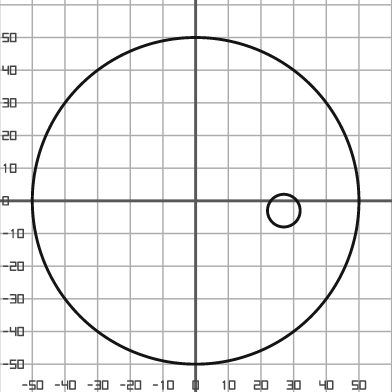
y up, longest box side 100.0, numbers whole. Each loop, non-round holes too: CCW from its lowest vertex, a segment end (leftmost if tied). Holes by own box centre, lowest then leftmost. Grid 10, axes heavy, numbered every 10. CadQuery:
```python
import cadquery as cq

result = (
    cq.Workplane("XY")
    .moveTo(0.0, 0.0)
    .circle(50.0)
    .moveTo(27.0, -3.0)
    .circle(5.0)
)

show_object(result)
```